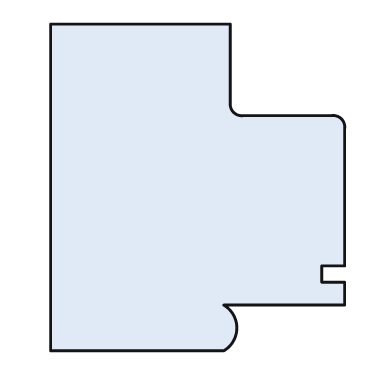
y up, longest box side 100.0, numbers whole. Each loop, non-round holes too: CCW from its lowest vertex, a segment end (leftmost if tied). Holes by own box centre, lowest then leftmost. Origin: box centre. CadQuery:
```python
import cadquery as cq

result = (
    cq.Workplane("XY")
    .moveTo(-45.0, -50.0)
    .lineTo(8.0, -50.0)
    .threePointArc((12.0, -43.0), (8.0, -36.0))
    .lineTo(45.0, -36.0)
    .lineTo(45.0, -29.0)
    .lineTo(38.0, -29.0)
    .lineTo(38.0, -24.0)
    .lineTo(45.0, -24.0)
    .lineTo(45.0, 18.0)
    .threePointArc((44.0, 21.0), (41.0, 22.0))
    .lineTo(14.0, 22.0)
    .threePointArc((11.0, 23.0), (10.0, 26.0))
    .lineTo(10.0, 50.0)
    .lineTo(-45.0, 50.0)
    .close()
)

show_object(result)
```